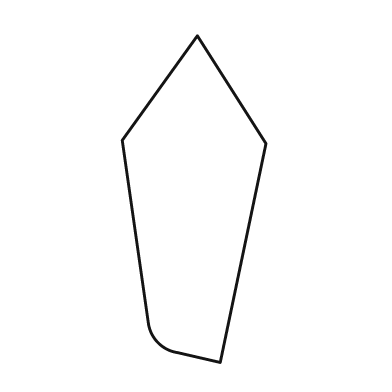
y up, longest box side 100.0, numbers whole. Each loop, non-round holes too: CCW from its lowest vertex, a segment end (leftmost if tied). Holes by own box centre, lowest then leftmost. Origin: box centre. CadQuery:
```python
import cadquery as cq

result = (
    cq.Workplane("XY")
    .moveTo(8.0, -50.0)
    .lineTo(22.0, 17.0)
    .lineTo(1.0, 50.0)
    .lineTo(-22.0, 18.0)
    .lineTo(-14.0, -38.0)
    .threePointArc((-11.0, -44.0), (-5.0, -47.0))
    .close()
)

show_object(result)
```